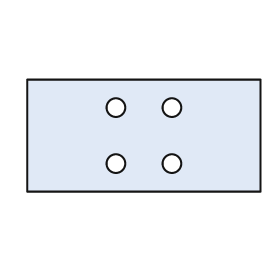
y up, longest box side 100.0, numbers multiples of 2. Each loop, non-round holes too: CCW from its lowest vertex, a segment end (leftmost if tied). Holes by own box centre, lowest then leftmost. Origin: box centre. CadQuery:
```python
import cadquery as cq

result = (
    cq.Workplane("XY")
    .moveTo(-50.0, -24.0)
    .lineTo(50.0, -24.0)
    .lineTo(50.0, 24.0)
    .lineTo(-50.0, 24.0)
    .close()
    .moveTo(-12.0, -12.0)
    .circle(4.0)
    .moveTo(12.0, -12.0)
    .circle(4.0)
    .moveTo(-12.0, 12.0)
    .circle(4.0)
    .moveTo(12.0, 12.0)
    .circle(4.0)
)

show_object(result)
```